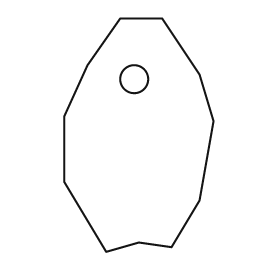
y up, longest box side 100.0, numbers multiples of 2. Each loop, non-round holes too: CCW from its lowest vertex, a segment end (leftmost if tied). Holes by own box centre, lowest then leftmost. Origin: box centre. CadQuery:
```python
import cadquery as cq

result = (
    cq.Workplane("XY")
    .moveTo(-14.0, -50.0)
    .lineTo(0.0, -46.0)
    .lineTo(14.0, -48.0)
    .lineTo(26.0, -28.0)
    .lineTo(32.0, 6.0)
    .lineTo(26.0, 26.0)
    .lineTo(10.0, 50.0)
    .lineTo(-8.0, 50.0)
    .lineTo(-22.0, 30.0)
    .lineTo(-32.0, 8.0)
    .lineTo(-32.0, -20.0)
    .close()
    .moveTo(-2.0, 24.0)
    .circle(6.0)
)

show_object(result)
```